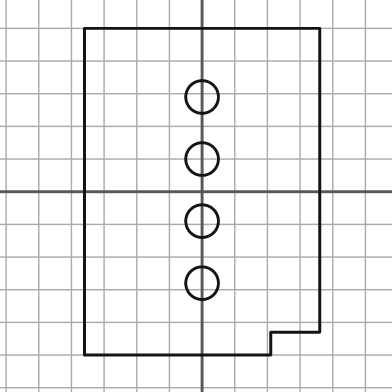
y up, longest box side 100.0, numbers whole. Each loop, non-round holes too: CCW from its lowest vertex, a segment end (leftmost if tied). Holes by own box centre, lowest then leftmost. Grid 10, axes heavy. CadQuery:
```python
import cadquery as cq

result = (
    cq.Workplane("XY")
    .moveTo(-36.0, -50.0)
    .lineTo(21.0, -50.0)
    .lineTo(21.0, -43.0)
    .lineTo(36.0, -43.0)
    .lineTo(36.0, 50.0)
    .lineTo(-36.0, 50.0)
    .close()
    .moveTo(0.0, -28.0)
    .circle(5.0)
    .moveTo(0.0, -9.0)
    .circle(5.0)
    .moveTo(0.0, 10.0)
    .circle(5.0)
    .moveTo(0.0, 29.0)
    .circle(5.0)
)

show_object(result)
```